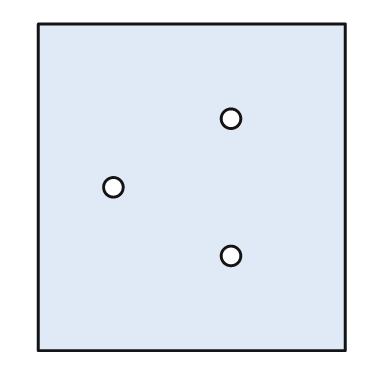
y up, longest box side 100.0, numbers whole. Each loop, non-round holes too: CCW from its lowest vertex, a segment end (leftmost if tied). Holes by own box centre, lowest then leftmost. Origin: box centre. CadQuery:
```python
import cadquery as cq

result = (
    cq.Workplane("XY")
    .moveTo(-47.0, -50.0)
    .lineTo(47.0, -50.0)
    .lineTo(47.0, 50.0)
    .lineTo(-47.0, 50.0)
    .close()
    .moveTo(12.0, -21.0)
    .circle(3.0)
    .moveTo(-24.0, 0.0)
    .circle(3.0)
    .moveTo(12.0, 21.0)
    .circle(3.0)
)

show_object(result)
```